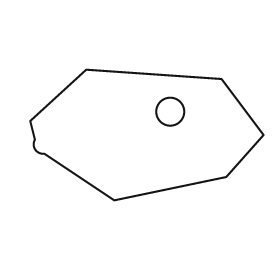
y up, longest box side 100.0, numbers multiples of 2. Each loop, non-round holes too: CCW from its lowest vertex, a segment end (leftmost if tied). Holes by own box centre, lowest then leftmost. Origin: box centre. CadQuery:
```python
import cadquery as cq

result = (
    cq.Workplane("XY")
    .moveTo(-14.0, -28.0)
    .lineTo(34.0, -18.0)
    .lineTo(50.0, 0.0)
    .lineTo(32.0, 24.0)
    .lineTo(-26.0, 28.0)
    .lineTo(-50.0, 6.0)
    .lineTo(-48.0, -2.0)
    .threePointArc((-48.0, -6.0), (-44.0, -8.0))
    .close()
    .moveTo(10.0, 10.0)
    .circle(6.0)
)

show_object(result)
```